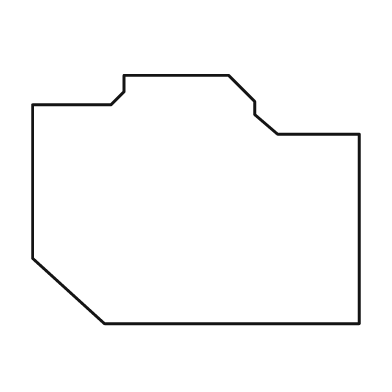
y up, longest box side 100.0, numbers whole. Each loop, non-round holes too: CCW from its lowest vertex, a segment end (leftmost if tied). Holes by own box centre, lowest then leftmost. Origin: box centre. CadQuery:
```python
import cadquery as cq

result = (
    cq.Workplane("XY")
    .moveTo(-28.0, -38.0)
    .lineTo(50.0, -38.0)
    .lineTo(50.0, 20.0)
    .lineTo(25.0, 20.0)
    .lineTo(18.0, 26.0)
    .lineTo(18.0, 30.0)
    .lineTo(10.0, 38.0)
    .lineTo(-22.0, 38.0)
    .lineTo(-22.0, 33.0)
    .lineTo(-26.0, 29.0)
    .lineTo(-50.0, 29.0)
    .lineTo(-50.0, -18.0)
    .close()
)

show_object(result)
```